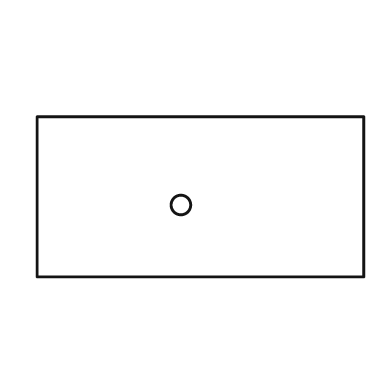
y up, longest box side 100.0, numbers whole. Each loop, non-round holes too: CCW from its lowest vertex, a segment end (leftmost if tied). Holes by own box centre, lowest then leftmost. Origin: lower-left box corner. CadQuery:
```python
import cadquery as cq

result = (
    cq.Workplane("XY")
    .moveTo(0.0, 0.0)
    .lineTo(100.0, 0.0)
    .lineTo(100.0, 49.0)
    .lineTo(0.0, 49.0)
    .close()
    .moveTo(44.0, 22.0)
    .circle(3.0)
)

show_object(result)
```